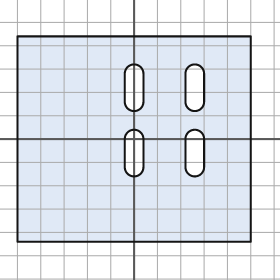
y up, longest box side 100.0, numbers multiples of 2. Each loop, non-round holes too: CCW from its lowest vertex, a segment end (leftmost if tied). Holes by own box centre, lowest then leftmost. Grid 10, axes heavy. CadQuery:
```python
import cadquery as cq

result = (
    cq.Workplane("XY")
    .moveTo(-50.0, -44.0)
    .lineTo(50.0, -44.0)
    .lineTo(50.0, 44.0)
    .lineTo(-50.0, 44.0)
    .close()
    .moveTo(-4.0, -12.0)
    .threePointArc((0.0, -16.0), (4.0, -12.0))
    .lineTo(4.0, 0.0)
    .threePointArc((0.0, 4.0), (-4.0, 0.0))
    .close()
    .moveTo(22.0, -12.0)
    .threePointArc((26.0, -16.0), (30.0, -12.0))
    .lineTo(30.0, 0.0)
    .threePointArc((26.0, 4.0), (22.0, 0.0))
    .close()
    .moveTo(-4.0, 16.0)
    .threePointArc((0.0, 12.0), (4.0, 16.0))
    .lineTo(4.0, 28.0)
    .threePointArc((0.0, 32.0), (-4.0, 28.0))
    .close()
    .moveTo(22.0, 16.0)
    .threePointArc((26.0, 12.0), (30.0, 16.0))
    .lineTo(30.0, 28.0)
    .threePointArc((26.0, 32.0), (22.0, 28.0))
    .close()
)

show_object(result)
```